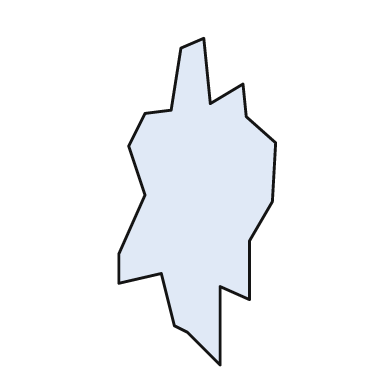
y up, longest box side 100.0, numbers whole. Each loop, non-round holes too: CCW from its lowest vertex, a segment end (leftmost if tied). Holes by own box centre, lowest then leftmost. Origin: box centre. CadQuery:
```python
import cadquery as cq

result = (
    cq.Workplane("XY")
    .moveTo(7.0, -50.0)
    .lineTo(7.0, -26.0)
    .lineTo(16.0, -30.0)
    .lineTo(16.0, -12.0)
    .lineTo(23.0, 0.0)
    .lineTo(24.0, 18.0)
    .lineTo(15.0, 26.0)
    .lineTo(14.0, 36.0)
    .lineTo(4.0, 30.0)
    .lineTo(2.0, 50.0)
    .lineTo(-5.0, 47.0)
    .lineTo(-8.0, 28.0)
    .lineTo(-16.0, 27.0)
    .lineTo(-21.0, 17.0)
    .lineTo(-16.0, 2.0)
    .lineTo(-24.0, -16.0)
    .lineTo(-24.0, -25.0)
    .lineTo(-11.0, -22.0)
    .lineTo(-7.0, -38.0)
    .lineTo(-3.0, -40.0)
    .close()
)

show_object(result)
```